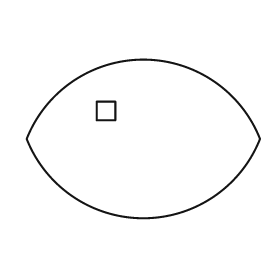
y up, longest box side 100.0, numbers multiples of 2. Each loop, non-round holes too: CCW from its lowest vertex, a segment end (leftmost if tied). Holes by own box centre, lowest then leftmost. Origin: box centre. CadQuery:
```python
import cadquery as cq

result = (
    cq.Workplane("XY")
    .moveTo(-50.0, 0.0)
    .threePointArc((0.0, -34.0), (50.0, 0.0))
    .threePointArc((0.0, 34.0), (-50.0, 0.0))
    .close()
    .moveTo(-20.0, 8.0)
    .lineTo(-12.0, 8.0)
    .lineTo(-12.0, 16.0)
    .lineTo(-20.0, 16.0)
    .close()
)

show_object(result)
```